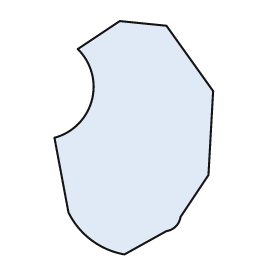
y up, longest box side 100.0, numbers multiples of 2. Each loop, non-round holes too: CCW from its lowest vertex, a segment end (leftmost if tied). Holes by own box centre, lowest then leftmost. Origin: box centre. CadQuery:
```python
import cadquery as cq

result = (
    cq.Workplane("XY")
    .moveTo(-4.0, -50.0)
    .lineTo(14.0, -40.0)
    .threePointArc((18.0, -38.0), (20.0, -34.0))
    .lineTo(32.0, -16.0)
    .lineTo(34.0, 20.0)
    .lineTo(14.0, 48.0)
    .lineTo(-6.0, 50.0)
    .lineTo(-24.0, 38.0)
    .threePointArc((-18.0, 16.0), (-34.0, 0.0))
    .lineTo(-28.0, -32.0)
    .threePointArc((-18.0, -44.0), (-4.0, -50.0))
    .close()
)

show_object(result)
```